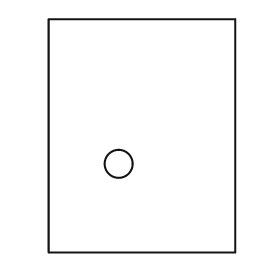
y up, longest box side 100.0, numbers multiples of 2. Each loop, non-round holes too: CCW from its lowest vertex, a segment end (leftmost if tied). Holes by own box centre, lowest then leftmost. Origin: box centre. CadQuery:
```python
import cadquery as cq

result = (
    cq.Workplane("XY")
    .moveTo(-40.0, -50.0)
    .lineTo(40.0, -50.0)
    .lineTo(40.0, 50.0)
    .lineTo(-40.0, 50.0)
    .close()
    .moveTo(-10.0, -12.0)
    .circle(6.0)
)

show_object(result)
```